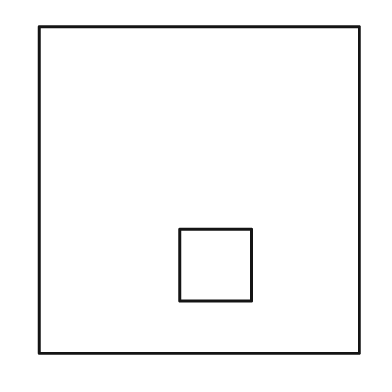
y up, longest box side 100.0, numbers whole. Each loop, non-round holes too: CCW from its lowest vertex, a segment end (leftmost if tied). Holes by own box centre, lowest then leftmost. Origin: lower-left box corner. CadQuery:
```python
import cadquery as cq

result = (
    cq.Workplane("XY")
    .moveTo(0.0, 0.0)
    .lineTo(98.0, 0.0)
    .lineTo(98.0, 100.0)
    .lineTo(0.0, 100.0)
    .close()
    .moveTo(43.0, 16.0)
    .lineTo(65.0, 16.0)
    .lineTo(65.0, 38.0)
    .lineTo(43.0, 38.0)
    .close()
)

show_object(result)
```